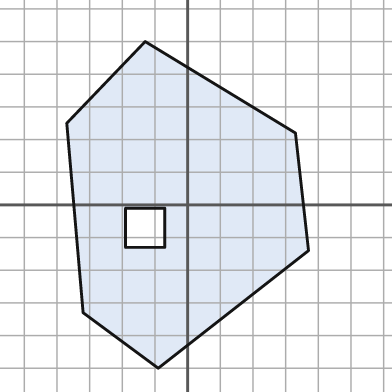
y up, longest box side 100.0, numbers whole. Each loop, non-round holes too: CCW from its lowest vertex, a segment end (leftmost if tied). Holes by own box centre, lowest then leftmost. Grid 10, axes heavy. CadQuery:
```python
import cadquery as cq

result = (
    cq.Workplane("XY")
    .moveTo(-9.0, -50.0)
    .lineTo(37.0, -14.0)
    .lineTo(33.0, 22.0)
    .lineTo(-13.0, 50.0)
    .lineTo(-37.0, 25.0)
    .lineTo(-32.0, -33.0)
    .close()
    .moveTo(-19.0, -13.0)
    .lineTo(-7.0, -13.0)
    .lineTo(-7.0, -1.0)
    .lineTo(-19.0, -1.0)
    .close()
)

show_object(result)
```